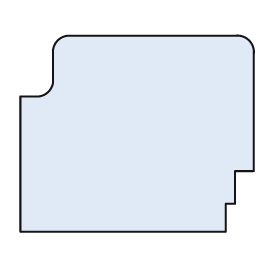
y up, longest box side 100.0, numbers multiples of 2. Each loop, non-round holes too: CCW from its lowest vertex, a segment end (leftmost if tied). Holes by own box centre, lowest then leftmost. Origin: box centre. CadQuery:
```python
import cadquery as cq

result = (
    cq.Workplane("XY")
    .moveTo(-50.0, -42.0)
    .lineTo(38.0, -42.0)
    .lineTo(38.0, -30.0)
    .lineTo(42.0, -30.0)
    .lineTo(42.0, -16.0)
    .lineTo(50.0, -16.0)
    .lineTo(50.0, 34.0)
    .threePointArc((48.0, 40.0), (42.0, 42.0))
    .lineTo(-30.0, 42.0)
    .threePointArc((-34.0, 40.0), (-36.0, 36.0))
    .lineTo(-36.0, 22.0)
    .threePointArc((-38.0, 18.0), (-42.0, 16.0))
    .lineTo(-50.0, 16.0)
    .close()
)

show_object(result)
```